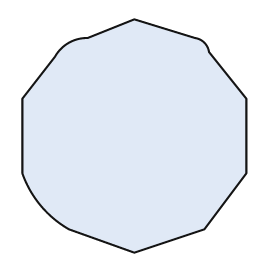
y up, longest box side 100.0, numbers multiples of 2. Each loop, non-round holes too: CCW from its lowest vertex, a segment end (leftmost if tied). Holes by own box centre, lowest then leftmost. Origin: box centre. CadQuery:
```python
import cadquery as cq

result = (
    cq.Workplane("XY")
    .moveTo(0.0, -50.0)
    .lineTo(30.0, -40.0)
    .lineTo(48.0, -16.0)
    .lineTo(48.0, 16.0)
    .lineTo(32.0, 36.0)
    .threePointArc((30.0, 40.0), (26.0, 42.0))
    .lineTo(0.0, 50.0)
    .lineTo(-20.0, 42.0)
    .threePointArc((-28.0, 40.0), (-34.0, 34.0))
    .lineTo(-48.0, 16.0)
    .lineTo(-48.0, -16.0)
    .threePointArc((-40.0, -30.0), (-28.0, -40.0))
    .close()
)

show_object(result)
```